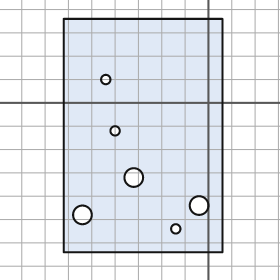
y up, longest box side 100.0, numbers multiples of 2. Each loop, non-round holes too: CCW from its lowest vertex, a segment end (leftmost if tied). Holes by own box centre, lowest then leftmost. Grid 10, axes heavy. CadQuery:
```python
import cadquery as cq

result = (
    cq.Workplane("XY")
    .moveTo(-62.0, -64.0)
    .lineTo(6.0, -64.0)
    .lineTo(6.0, 36.0)
    .lineTo(-62.0, 36.0)
    .close()
    .moveTo(-14.0, -54.0)
    .circle(2.0)
    .moveTo(-54.0, -48.0)
    .circle(4.0)
    .moveTo(-4.0, -44.0)
    .circle(4.0)
    .moveTo(-32.0, -32.0)
    .circle(4.0)
    .moveTo(-40.0, -12.0)
    .circle(2.0)
    .moveTo(-44.0, 10.0)
    .circle(2.0)
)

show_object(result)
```